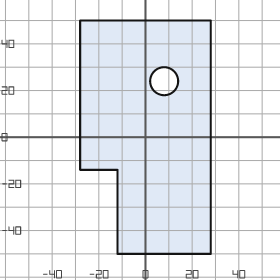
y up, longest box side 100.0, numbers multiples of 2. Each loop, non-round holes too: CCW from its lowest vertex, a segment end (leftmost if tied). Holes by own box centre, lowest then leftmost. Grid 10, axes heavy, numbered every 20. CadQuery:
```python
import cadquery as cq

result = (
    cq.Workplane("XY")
    .moveTo(-12.0, -50.0)
    .lineTo(28.0, -50.0)
    .lineTo(28.0, 50.0)
    .lineTo(-28.0, 50.0)
    .lineTo(-28.0, -14.0)
    .lineTo(-12.0, -14.0)
    .close()
    .moveTo(8.0, 24.0)
    .circle(6.0)
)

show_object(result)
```